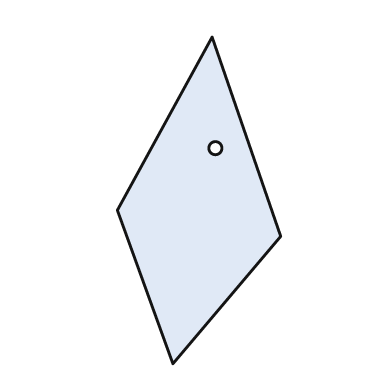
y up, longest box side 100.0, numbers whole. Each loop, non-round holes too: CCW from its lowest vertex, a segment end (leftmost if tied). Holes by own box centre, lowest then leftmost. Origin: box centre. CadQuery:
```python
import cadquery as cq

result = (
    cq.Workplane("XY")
    .moveTo(-8.0, -50.0)
    .lineTo(25.0, -11.0)
    .lineTo(4.0, 50.0)
    .lineTo(-25.0, -3.0)
    .close()
    .moveTo(5.0, 16.0)
    .circle(2.0)
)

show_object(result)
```